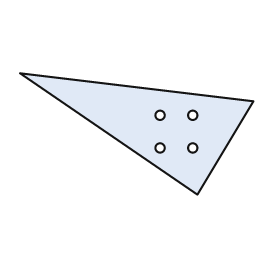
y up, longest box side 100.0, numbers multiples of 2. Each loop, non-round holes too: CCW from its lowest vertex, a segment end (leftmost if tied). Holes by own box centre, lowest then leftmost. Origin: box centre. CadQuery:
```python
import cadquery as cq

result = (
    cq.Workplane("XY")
    .moveTo(26.0, -26.0)
    .lineTo(50.0, 14.0)
    .lineTo(-50.0, 26.0)
    .close()
    .moveTo(10.0, -6.0)
    .circle(2.0)
    .moveTo(24.0, -6.0)
    .circle(2.0)
    .moveTo(10.0, 8.0)
    .circle(2.0)
    .moveTo(24.0, 8.0)
    .circle(2.0)
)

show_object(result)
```